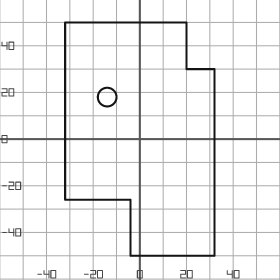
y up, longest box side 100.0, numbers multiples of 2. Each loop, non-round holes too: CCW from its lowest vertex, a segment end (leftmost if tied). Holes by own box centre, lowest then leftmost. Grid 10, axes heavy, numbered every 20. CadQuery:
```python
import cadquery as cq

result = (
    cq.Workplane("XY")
    .moveTo(-4.0, -50.0)
    .lineTo(32.0, -50.0)
    .lineTo(32.0, 30.0)
    .lineTo(20.0, 30.0)
    .lineTo(20.0, 50.0)
    .lineTo(-32.0, 50.0)
    .lineTo(-32.0, -26.0)
    .lineTo(-4.0, -26.0)
    .close()
    .moveTo(-14.0, 18.0)
    .circle(4.0)
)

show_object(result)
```